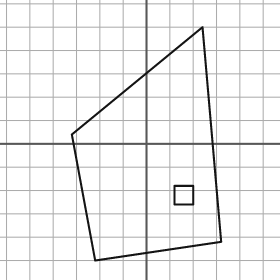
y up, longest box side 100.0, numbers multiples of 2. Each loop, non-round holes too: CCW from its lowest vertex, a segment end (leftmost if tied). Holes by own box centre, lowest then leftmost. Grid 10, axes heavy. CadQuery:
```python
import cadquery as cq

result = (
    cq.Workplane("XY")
    .moveTo(-22.0, -50.0)
    .lineTo(32.0, -42.0)
    .lineTo(24.0, 50.0)
    .lineTo(-32.0, 4.0)
    .close()
    .moveTo(12.0, -26.0)
    .lineTo(20.0, -26.0)
    .lineTo(20.0, -18.0)
    .lineTo(12.0, -18.0)
    .close()
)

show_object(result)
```